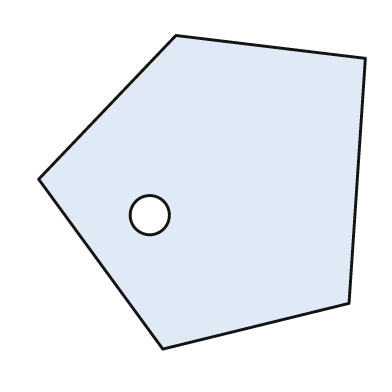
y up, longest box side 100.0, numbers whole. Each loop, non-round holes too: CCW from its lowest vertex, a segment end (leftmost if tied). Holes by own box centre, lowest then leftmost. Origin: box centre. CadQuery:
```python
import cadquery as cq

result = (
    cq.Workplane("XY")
    .moveTo(-12.0, -48.0)
    .lineTo(45.0, -34.0)
    .lineTo(50.0, 41.0)
    .lineTo(-8.0, 48.0)
    .lineTo(-50.0, 4.0)
    .close()
    .moveTo(-16.0, -7.0)
    .circle(6.0)
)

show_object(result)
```